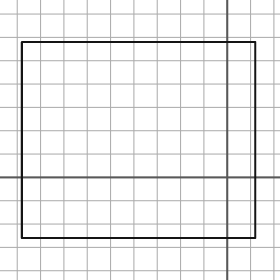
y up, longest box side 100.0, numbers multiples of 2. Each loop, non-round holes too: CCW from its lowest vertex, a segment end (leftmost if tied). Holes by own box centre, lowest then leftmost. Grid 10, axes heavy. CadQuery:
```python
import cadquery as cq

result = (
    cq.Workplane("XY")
    .moveTo(-88.0, -26.0)
    .lineTo(12.0, -26.0)
    .lineTo(12.0, 58.0)
    .lineTo(-88.0, 58.0)
    .close()
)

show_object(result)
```